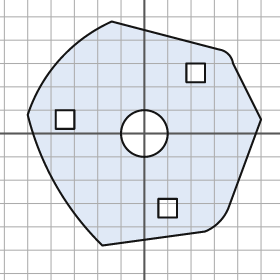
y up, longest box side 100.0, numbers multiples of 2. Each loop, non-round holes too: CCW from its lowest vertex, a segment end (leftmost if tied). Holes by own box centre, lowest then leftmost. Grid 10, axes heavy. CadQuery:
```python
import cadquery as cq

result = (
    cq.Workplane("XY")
    .moveTo(-18.0, -48.0)
    .lineTo(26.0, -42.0)
    .threePointArc((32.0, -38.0), (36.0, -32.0))
    .lineTo(50.0, 6.0)
    .lineTo(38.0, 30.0)
    .threePointArc((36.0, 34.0), (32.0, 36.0))
    .lineTo(-14.0, 48.0)
    .threePointArc((-36.0, 32.0), (-50.0, 8.0))
    .threePointArc((-38.0, -22.0), (-18.0, -48.0))
    .close()
    .moveTo(6.0, -36.0)
    .lineTo(14.0, -36.0)
    .lineTo(14.0, -28.0)
    .lineTo(6.0, -28.0)
    .close()
    .moveTo(0.0, 0.0)
    .circle(10.0)
    .moveTo(-38.0, 2.0)
    .lineTo(-30.0, 2.0)
    .lineTo(-30.0, 10.0)
    .lineTo(-38.0, 10.0)
    .close()
    .moveTo(18.0, 22.0)
    .lineTo(26.0, 22.0)
    .lineTo(26.0, 30.0)
    .lineTo(18.0, 30.0)
    .close()
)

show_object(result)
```